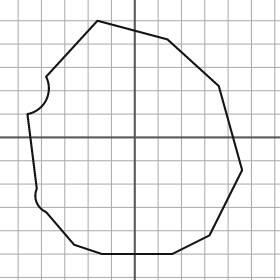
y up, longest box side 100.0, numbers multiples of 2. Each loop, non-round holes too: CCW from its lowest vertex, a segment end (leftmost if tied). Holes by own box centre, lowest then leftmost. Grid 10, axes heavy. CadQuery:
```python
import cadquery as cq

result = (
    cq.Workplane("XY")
    .moveTo(-14.0, -50.0)
    .lineTo(16.0, -50.0)
    .lineTo(32.0, -42.0)
    .lineTo(46.0, -14.0)
    .lineTo(36.0, 22.0)
    .lineTo(14.0, 42.0)
    .lineTo(-16.0, 50.0)
    .lineTo(-38.0, 26.0)
    .threePointArc((-38.0, 16.0), (-46.0, 10.0))
    .lineTo(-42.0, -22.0)
    .threePointArc((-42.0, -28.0), (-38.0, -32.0))
    .lineTo(-26.0, -46.0)
    .close()
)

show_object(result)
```